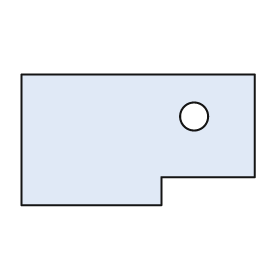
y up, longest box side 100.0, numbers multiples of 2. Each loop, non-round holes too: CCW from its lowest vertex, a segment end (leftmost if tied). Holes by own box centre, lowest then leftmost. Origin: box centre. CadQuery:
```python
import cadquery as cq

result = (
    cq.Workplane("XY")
    .moveTo(-50.0, -28.0)
    .lineTo(10.0, -28.0)
    .lineTo(10.0, -16.0)
    .lineTo(50.0, -16.0)
    .lineTo(50.0, 28.0)
    .lineTo(-50.0, 28.0)
    .close()
    .moveTo(24.0, 10.0)
    .circle(6.0)
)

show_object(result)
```